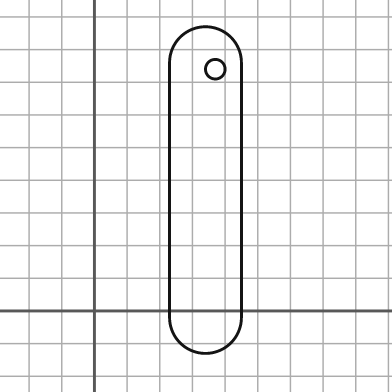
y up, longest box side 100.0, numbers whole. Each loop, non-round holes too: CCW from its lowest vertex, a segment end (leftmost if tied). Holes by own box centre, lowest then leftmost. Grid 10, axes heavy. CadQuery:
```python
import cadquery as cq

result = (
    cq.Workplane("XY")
    .moveTo(23.0, -2.0)
    .threePointArc((34.0, -13.0), (45.0, -2.0))
    .lineTo(45.0, 76.0)
    .threePointArc((34.0, 87.0), (23.0, 76.0))
    .close()
    .moveTo(37.0, 74.0)
    .circle(3.0)
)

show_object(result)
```